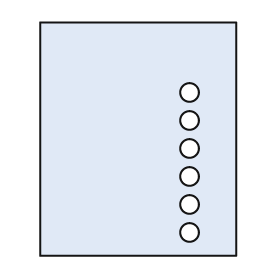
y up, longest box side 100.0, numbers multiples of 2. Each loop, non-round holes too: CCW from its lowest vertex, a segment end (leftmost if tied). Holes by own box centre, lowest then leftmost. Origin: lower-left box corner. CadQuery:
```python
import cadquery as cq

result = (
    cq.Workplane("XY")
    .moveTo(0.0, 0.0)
    .lineTo(84.0, 0.0)
    .lineTo(84.0, 100.0)
    .lineTo(0.0, 100.0)
    .close()
    .moveTo(64.0, 10.0)
    .circle(4.0)
    .moveTo(64.0, 22.0)
    .circle(4.0)
    .moveTo(64.0, 34.0)
    .circle(4.0)
    .moveTo(64.0, 46.0)
    .circle(4.0)
    .moveTo(64.0, 58.0)
    .circle(4.0)
    .moveTo(64.0, 70.0)
    .circle(4.0)
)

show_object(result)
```